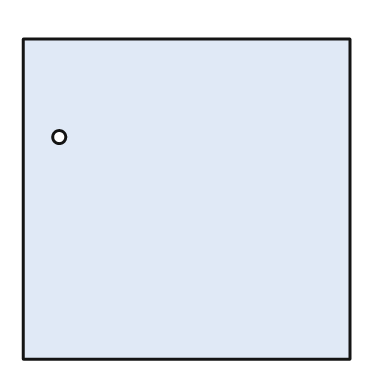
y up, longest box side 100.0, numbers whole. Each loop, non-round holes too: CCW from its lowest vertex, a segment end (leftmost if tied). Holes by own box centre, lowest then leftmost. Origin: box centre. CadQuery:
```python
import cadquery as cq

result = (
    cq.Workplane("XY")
    .moveTo(-50.0, -49.0)
    .lineTo(50.0, -49.0)
    .lineTo(50.0, 49.0)
    .lineTo(-50.0, 49.0)
    .close()
    .moveTo(-39.0, 19.0)
    .circle(2.0)
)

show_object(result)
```